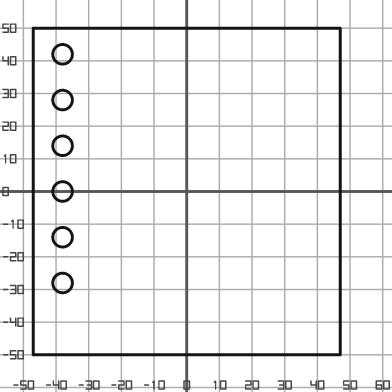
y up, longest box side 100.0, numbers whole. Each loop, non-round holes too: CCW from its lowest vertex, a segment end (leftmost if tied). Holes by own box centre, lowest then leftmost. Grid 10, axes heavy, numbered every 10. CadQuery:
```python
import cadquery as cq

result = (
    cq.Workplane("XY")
    .moveTo(-47.0, -50.0)
    .lineTo(47.0, -50.0)
    .lineTo(47.0, 50.0)
    .lineTo(-47.0, 50.0)
    .close()
    .moveTo(-38.0, -28.0)
    .circle(3.0)
    .moveTo(-38.0, -14.0)
    .circle(3.0)
    .moveTo(-38.0, 0.0)
    .circle(3.0)
    .moveTo(-38.0, 14.0)
    .circle(3.0)
    .moveTo(-38.0, 28.0)
    .circle(3.0)
    .moveTo(-38.0, 42.0)
    .circle(3.0)
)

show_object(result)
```